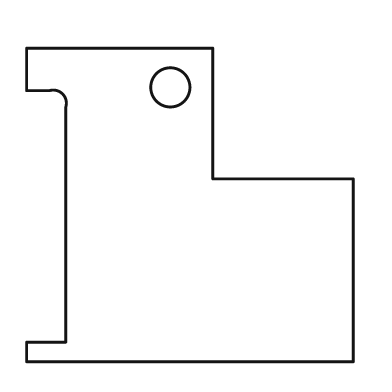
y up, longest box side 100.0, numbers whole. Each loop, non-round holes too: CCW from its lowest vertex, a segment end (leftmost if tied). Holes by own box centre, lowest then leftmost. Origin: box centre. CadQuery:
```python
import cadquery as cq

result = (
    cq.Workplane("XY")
    .moveTo(-50.0, -48.0)
    .lineTo(50.0, -48.0)
    .lineTo(50.0, 8.0)
    .lineTo(7.0, 8.0)
    .lineTo(7.0, 48.0)
    .lineTo(-50.0, 48.0)
    .lineTo(-50.0, 35.0)
    .lineTo(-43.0, 35.0)
    .threePointArc((-39.0, 34.0), (-38.0, 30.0))
    .lineTo(-38.0, -42.0)
    .lineTo(-50.0, -42.0)
    .close()
    .moveTo(-6.0, 36.0)
    .circle(6.0)
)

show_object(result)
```